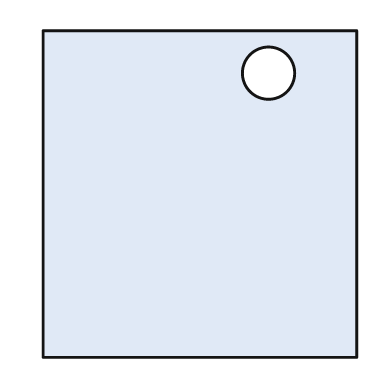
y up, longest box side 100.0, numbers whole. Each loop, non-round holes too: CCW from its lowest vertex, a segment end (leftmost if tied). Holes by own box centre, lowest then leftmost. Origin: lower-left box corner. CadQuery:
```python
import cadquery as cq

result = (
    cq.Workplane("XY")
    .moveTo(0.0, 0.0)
    .lineTo(96.0, 0.0)
    .lineTo(96.0, 100.0)
    .lineTo(0.0, 100.0)
    .close()
    .moveTo(69.0, 87.0)
    .circle(8.0)
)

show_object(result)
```